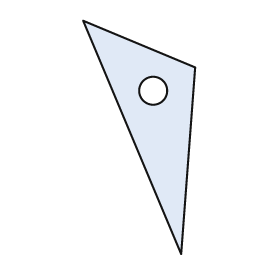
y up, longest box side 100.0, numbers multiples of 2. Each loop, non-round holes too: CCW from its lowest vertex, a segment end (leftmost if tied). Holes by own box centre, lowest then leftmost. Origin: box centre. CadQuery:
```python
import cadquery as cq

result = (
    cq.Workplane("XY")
    .moveTo(18.0, -50.0)
    .lineTo(24.0, 30.0)
    .lineTo(-24.0, 50.0)
    .close()
    .moveTo(6.0, 20.0)
    .circle(6.0)
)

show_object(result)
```